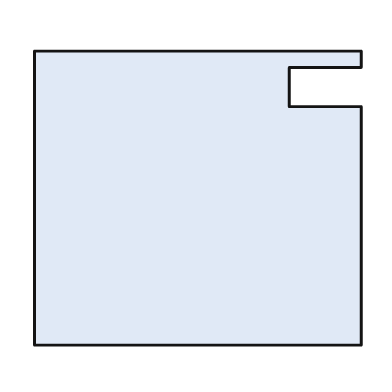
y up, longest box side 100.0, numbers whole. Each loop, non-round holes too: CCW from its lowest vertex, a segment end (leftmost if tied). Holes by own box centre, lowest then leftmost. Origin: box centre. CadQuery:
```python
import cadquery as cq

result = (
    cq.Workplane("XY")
    .moveTo(-50.0, -45.0)
    .lineTo(50.0, -45.0)
    .lineTo(50.0, 28.0)
    .lineTo(28.0, 28.0)
    .lineTo(28.0, 40.0)
    .lineTo(50.0, 40.0)
    .lineTo(50.0, 45.0)
    .lineTo(-50.0, 45.0)
    .close()
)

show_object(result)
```